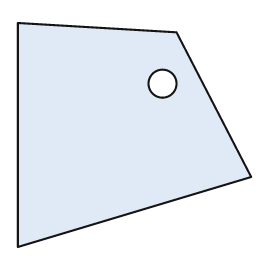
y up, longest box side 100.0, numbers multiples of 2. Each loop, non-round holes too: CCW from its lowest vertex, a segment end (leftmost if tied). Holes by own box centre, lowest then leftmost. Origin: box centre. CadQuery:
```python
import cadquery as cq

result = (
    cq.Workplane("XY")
    .moveTo(-50.0, -48.0)
    .lineTo(50.0, -18.0)
    .lineTo(18.0, 44.0)
    .lineTo(-50.0, 48.0)
    .close()
    .moveTo(12.0, 22.0)
    .circle(6.0)
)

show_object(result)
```